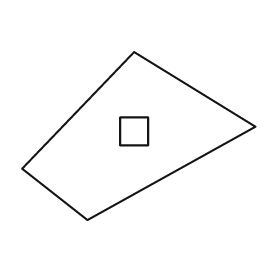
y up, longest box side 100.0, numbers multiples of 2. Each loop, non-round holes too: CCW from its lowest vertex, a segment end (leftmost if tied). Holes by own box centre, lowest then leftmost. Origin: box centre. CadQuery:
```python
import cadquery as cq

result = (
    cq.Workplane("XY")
    .moveTo(-22.0, -36.0)
    .lineTo(50.0, 4.0)
    .lineTo(-2.0, 36.0)
    .lineTo(-50.0, -14.0)
    .close()
    .moveTo(-8.0, -4.0)
    .lineTo(4.0, -4.0)
    .lineTo(4.0, 8.0)
    .lineTo(-8.0, 8.0)
    .close()
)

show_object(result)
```